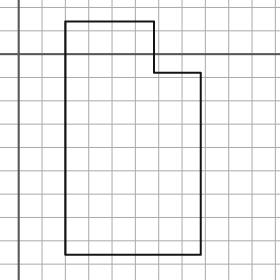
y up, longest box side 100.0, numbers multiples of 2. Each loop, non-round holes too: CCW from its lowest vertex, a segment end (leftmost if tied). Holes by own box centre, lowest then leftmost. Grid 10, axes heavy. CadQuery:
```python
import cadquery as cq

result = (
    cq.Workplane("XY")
    .moveTo(20.0, -86.0)
    .lineTo(78.0, -86.0)
    .lineTo(78.0, -8.0)
    .lineTo(58.0, -8.0)
    .lineTo(58.0, 14.0)
    .lineTo(20.0, 14.0)
    .close()
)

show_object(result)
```